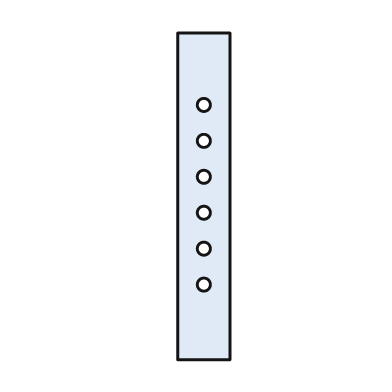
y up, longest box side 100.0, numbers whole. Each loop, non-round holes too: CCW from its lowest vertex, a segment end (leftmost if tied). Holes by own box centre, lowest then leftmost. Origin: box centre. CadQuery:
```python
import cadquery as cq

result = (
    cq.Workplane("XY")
    .moveTo(-8.0, -50.0)
    .lineTo(8.0, -50.0)
    .lineTo(8.0, 50.0)
    .lineTo(-8.0, 50.0)
    .close()
    .moveTo(0.0, -27.0)
    .circle(2.0)
    .moveTo(0.0, -16.0)
    .circle(2.0)
    .moveTo(0.0, -5.0)
    .circle(2.0)
    .moveTo(0.0, 6.0)
    .circle(2.0)
    .moveTo(0.0, 17.0)
    .circle(2.0)
    .moveTo(0.0, 28.0)
    .circle(2.0)
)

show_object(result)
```